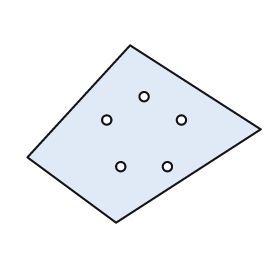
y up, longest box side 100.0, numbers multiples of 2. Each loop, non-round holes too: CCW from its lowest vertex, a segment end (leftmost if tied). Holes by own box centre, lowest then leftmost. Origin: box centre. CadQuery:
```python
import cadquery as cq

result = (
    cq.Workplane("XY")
    .moveTo(-12.0, -38.0)
    .lineTo(50.0, 2.0)
    .lineTo(-6.0, 38.0)
    .lineTo(-50.0, -10.0)
    .close()
    .moveTo(-10.0, -14.0)
    .circle(2.0)
    .moveTo(10.0, -14.0)
    .circle(2.0)
    .moveTo(-16.0, 6.0)
    .circle(2.0)
    .moveTo(16.0, 6.0)
    .circle(2.0)
    .moveTo(0.0, 16.0)
    .circle(2.0)
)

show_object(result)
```